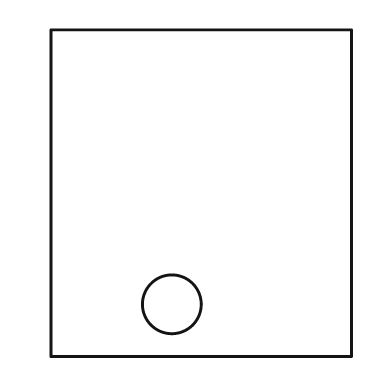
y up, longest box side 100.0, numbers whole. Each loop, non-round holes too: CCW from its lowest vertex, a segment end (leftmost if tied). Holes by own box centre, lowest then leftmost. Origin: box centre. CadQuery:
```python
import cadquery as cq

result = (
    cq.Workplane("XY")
    .moveTo(-46.0, -50.0)
    .lineTo(46.0, -50.0)
    .lineTo(46.0, 50.0)
    .lineTo(-46.0, 50.0)
    .close()
    .moveTo(-9.0, -34.0)
    .circle(9.0)
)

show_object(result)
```